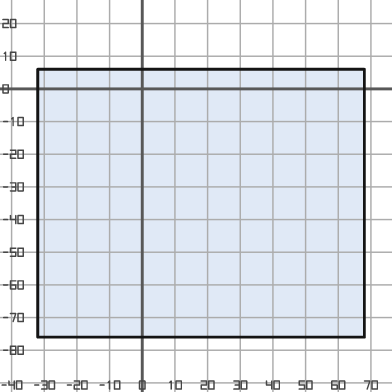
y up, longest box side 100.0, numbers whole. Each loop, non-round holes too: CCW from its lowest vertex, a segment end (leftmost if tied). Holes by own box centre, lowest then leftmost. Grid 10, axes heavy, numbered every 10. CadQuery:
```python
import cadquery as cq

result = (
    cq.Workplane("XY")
    .moveTo(-32.0, -76.0)
    .lineTo(68.0, -76.0)
    .lineTo(68.0, 6.0)
    .lineTo(-32.0, 6.0)
    .close()
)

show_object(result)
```